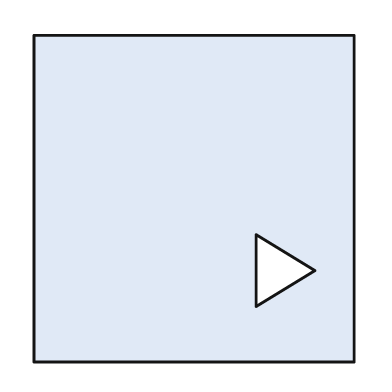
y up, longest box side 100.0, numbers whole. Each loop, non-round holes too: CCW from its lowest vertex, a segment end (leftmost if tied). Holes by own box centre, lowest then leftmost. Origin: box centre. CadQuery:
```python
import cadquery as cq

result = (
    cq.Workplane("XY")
    .moveTo(-49.0, -50.0)
    .lineTo(49.0, -50.0)
    .lineTo(49.0, 50.0)
    .lineTo(-49.0, 50.0)
    .close()
    .moveTo(19.0, -33.0)
    .lineTo(37.0, -22.0)
    .lineTo(19.0, -11.0)
    .close()
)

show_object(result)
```